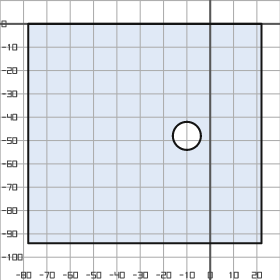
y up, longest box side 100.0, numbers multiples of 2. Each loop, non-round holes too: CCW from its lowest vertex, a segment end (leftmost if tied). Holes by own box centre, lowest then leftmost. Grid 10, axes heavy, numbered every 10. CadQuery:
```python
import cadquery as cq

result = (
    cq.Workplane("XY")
    .moveTo(-78.0, -94.0)
    .lineTo(22.0, -94.0)
    .lineTo(22.0, 0.0)
    .lineTo(-78.0, 0.0)
    .close()
    .moveTo(-10.0, -48.0)
    .circle(6.0)
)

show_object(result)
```